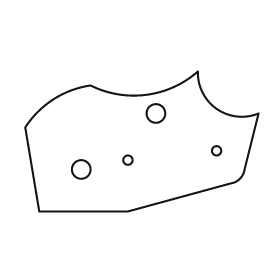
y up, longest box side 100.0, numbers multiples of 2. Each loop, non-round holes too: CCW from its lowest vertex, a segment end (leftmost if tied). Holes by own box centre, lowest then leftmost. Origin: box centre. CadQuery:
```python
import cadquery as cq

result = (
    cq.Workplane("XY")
    .moveTo(-44.0, -30.0)
    .lineTo(-6.0, -30.0)
    .lineTo(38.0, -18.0)
    .threePointArc((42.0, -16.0), (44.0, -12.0))
    .lineTo(50.0, 12.0)
    .threePointArc((32.0, 14.0), (24.0, 30.0))
    .threePointArc((2.0, 20.0), (-22.0, 24.0))
    .threePointArc((-38.0, 18.0), (-50.0, 6.0))
    .close()
    .moveTo(-26.0, -12.0)
    .circle(4.0)
    .moveTo(-6.0, -8.0)
    .circle(2.0)
    .moveTo(32.0, -4.0)
    .circle(2.0)
    .moveTo(6.0, 12.0)
    .circle(4.0)
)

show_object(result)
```